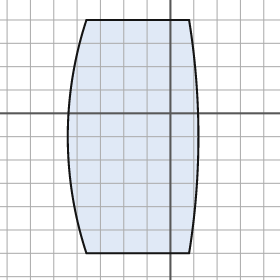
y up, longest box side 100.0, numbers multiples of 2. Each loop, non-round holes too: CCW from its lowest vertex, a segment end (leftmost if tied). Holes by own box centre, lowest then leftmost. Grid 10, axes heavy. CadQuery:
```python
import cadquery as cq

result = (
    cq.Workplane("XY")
    .moveTo(-36.0, -60.0)
    .lineTo(8.0, -60.0)
    .threePointArc((12.0, -10.0), (8.0, 40.0))
    .lineTo(-36.0, 40.0)
    .threePointArc((-44.0, -10.0), (-36.0, -60.0))
    .close()
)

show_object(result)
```